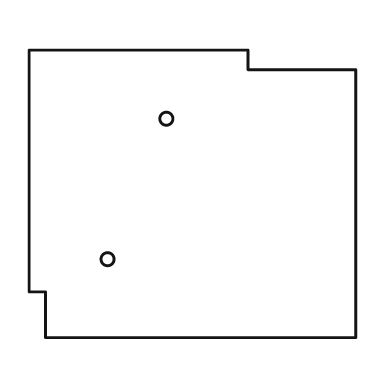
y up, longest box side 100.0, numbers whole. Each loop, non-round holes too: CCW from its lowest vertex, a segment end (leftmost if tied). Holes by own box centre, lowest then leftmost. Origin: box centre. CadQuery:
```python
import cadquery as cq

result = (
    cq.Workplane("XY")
    .moveTo(-45.0, -44.0)
    .lineTo(50.0, -44.0)
    .lineTo(50.0, 38.0)
    .lineTo(17.0, 38.0)
    .lineTo(17.0, 44.0)
    .lineTo(-50.0, 44.0)
    .lineTo(-50.0, -30.0)
    .lineTo(-45.0, -30.0)
    .close()
    .moveTo(-26.0, -20.0)
    .circle(2.0)
    .moveTo(-8.0, 23.0)
    .circle(2.0)
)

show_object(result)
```